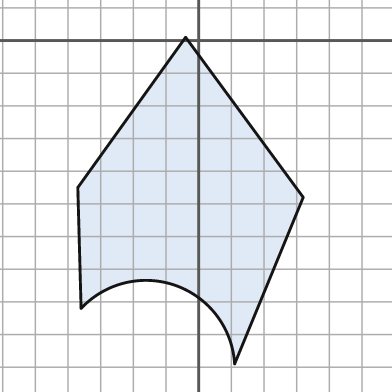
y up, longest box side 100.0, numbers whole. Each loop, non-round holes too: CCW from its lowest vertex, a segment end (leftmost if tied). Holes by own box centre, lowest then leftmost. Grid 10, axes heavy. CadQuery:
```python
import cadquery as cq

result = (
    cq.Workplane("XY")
    .moveTo(11.0, -99.0)
    .lineTo(32.0, -48.0)
    .lineTo(-4.0, 1.0)
    .lineTo(-37.0, -45.0)
    .lineTo(-36.0, -82.0)
    .threePointArc((-7.0, -75.0), (11.0, -99.0))
    .close()
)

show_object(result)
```